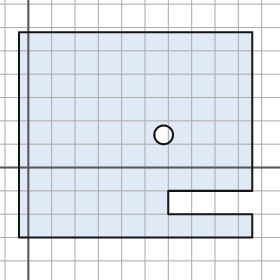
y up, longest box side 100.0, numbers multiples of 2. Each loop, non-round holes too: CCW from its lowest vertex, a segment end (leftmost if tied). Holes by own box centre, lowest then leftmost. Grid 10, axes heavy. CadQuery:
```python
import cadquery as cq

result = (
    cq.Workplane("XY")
    .moveTo(-4.0, -30.0)
    .lineTo(96.0, -30.0)
    .lineTo(96.0, -20.0)
    .lineTo(60.0, -20.0)
    .lineTo(60.0, -10.0)
    .lineTo(96.0, -10.0)
    .lineTo(96.0, 58.0)
    .lineTo(-4.0, 58.0)
    .close()
    .moveTo(58.0, 14.0)
    .circle(4.0)
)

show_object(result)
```